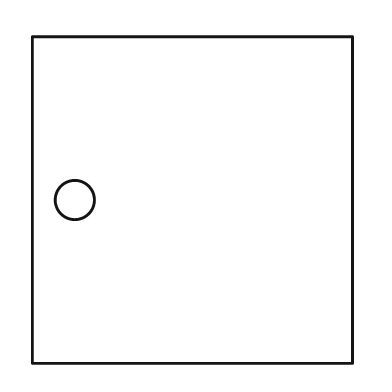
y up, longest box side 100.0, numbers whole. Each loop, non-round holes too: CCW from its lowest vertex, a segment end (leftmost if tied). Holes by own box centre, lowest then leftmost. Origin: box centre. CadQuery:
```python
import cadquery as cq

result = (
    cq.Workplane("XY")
    .moveTo(-49.0, -50.0)
    .lineTo(49.0, -50.0)
    .lineTo(49.0, 50.0)
    .lineTo(-49.0, 50.0)
    .close()
    .moveTo(-36.0, 0.0)
    .circle(6.0)
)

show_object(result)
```